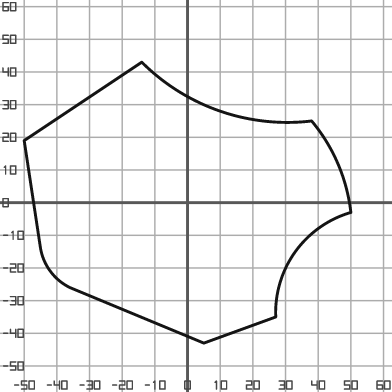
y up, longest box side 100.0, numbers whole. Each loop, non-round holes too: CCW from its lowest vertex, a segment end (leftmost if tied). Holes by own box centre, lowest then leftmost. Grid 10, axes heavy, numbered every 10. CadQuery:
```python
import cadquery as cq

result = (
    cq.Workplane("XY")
    .moveTo(5.0, -43.0)
    .lineTo(27.0, -35.0)
    .threePointArc((33.0, -15.0), (50.0, -3.0))
    .threePointArc((46.0, 12.0), (38.0, 25.0))
    .threePointArc((10.0, 28.0), (-14.0, 43.0))
    .lineTo(-50.0, 19.0)
    .lineTo(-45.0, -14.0)
    .threePointArc((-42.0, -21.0), (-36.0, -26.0))
    .close()
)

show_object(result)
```